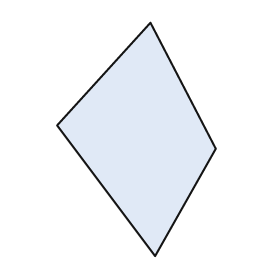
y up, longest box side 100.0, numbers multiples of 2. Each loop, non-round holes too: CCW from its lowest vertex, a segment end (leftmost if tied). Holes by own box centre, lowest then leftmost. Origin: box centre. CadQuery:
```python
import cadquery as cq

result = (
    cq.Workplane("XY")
    .moveTo(8.0, -50.0)
    .lineTo(34.0, -4.0)
    .lineTo(6.0, 50.0)
    .lineTo(-34.0, 6.0)
    .close()
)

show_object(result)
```